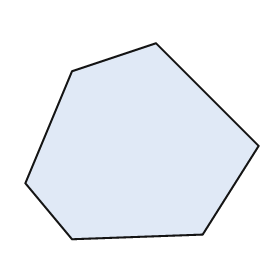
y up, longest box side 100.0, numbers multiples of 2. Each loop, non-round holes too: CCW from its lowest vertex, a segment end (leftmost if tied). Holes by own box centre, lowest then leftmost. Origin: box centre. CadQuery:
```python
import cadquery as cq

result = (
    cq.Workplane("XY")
    .moveTo(-30.0, -42.0)
    .lineTo(26.0, -40.0)
    .lineTo(50.0, -2.0)
    .lineTo(6.0, 42.0)
    .lineTo(-30.0, 30.0)
    .lineTo(-50.0, -18.0)
    .close()
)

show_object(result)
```